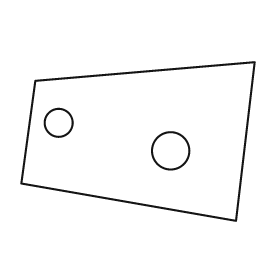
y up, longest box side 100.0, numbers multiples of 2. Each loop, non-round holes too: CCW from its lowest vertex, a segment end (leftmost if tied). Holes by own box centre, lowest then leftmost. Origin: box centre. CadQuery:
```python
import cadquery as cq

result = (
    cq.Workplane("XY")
    .moveTo(42.0, -34.0)
    .lineTo(50.0, 34.0)
    .lineTo(-44.0, 26.0)
    .lineTo(-50.0, -18.0)
    .close()
    .moveTo(14.0, -4.0)
    .circle(8.0)
    .moveTo(-34.0, 8.0)
    .circle(6.0)
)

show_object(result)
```